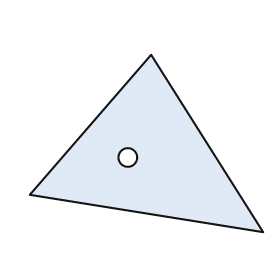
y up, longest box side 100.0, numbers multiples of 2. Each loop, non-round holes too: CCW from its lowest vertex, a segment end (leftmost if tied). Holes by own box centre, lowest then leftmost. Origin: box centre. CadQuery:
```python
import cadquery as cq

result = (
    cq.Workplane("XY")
    .moveTo(50.0, -38.0)
    .lineTo(2.0, 38.0)
    .lineTo(-50.0, -22.0)
    .close()
    .moveTo(-8.0, -6.0)
    .circle(4.0)
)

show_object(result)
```